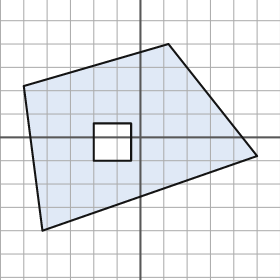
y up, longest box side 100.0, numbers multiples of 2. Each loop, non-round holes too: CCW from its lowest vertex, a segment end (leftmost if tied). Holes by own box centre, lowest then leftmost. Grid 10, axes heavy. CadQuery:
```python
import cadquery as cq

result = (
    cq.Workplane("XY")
    .moveTo(-42.0, -40.0)
    .lineTo(50.0, -8.0)
    .lineTo(12.0, 40.0)
    .lineTo(-50.0, 22.0)
    .close()
    .moveTo(-20.0, -10.0)
    .lineTo(-4.0, -10.0)
    .lineTo(-4.0, 6.0)
    .lineTo(-20.0, 6.0)
    .close()
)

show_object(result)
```